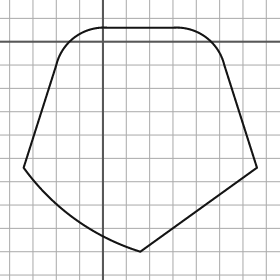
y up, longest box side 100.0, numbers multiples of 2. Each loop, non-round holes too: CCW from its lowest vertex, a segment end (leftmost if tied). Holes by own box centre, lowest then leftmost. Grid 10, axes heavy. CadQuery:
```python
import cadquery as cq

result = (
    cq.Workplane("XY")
    .moveTo(16.0, -90.0)
    .lineTo(66.0, -54.0)
    .lineTo(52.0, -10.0)
    .threePointArc((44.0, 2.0), (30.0, 6.0))
    .lineTo(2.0, 6.0)
    .threePointArc((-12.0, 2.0), (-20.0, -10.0))
    .lineTo(-34.0, -54.0)
    .threePointArc((-12.0, -76.0), (16.0, -90.0))
    .close()
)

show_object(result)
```